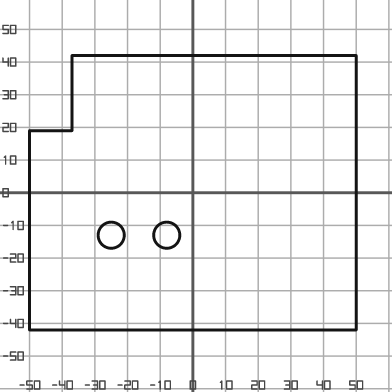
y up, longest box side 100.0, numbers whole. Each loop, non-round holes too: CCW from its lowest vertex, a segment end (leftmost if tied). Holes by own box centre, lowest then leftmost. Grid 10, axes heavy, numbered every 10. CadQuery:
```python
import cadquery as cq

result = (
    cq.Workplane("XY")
    .moveTo(-50.0, -42.0)
    .lineTo(50.0, -42.0)
    .lineTo(50.0, 42.0)
    .lineTo(-37.0, 42.0)
    .lineTo(-37.0, 19.0)
    .lineTo(-50.0, 19.0)
    .close()
    .moveTo(-25.0, -13.0)
    .circle(4.0)
    .moveTo(-8.0, -13.0)
    .circle(4.0)
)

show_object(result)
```